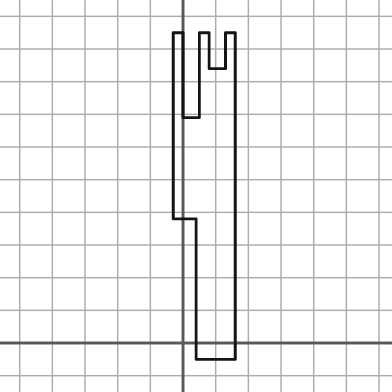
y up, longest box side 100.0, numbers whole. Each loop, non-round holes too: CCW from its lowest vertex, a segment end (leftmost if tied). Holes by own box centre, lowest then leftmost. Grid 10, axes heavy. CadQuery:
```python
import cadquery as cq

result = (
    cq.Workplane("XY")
    .moveTo(4.0, -5.0)
    .lineTo(16.0, -5.0)
    .lineTo(16.0, 95.0)
    .lineTo(13.0, 95.0)
    .lineTo(13.0, 84.0)
    .lineTo(8.0, 84.0)
    .lineTo(8.0, 95.0)
    .lineTo(5.0, 95.0)
    .lineTo(5.0, 69.0)
    .lineTo(0.0, 69.0)
    .lineTo(0.0, 95.0)
    .lineTo(-3.0, 95.0)
    .lineTo(-3.0, 38.0)
    .lineTo(4.0, 38.0)
    .close()
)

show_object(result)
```